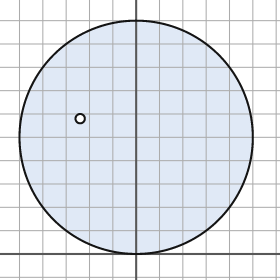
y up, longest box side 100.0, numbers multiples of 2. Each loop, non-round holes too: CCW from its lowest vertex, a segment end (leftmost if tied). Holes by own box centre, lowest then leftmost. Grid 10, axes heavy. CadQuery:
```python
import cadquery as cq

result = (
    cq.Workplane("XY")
    .moveTo(0.0, 50.0)
    .circle(50.0)
    .moveTo(-24.0, 58.0)
    .circle(2.0)
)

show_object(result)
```